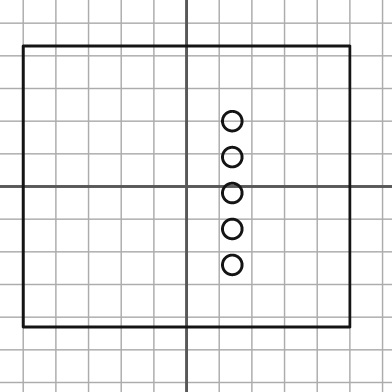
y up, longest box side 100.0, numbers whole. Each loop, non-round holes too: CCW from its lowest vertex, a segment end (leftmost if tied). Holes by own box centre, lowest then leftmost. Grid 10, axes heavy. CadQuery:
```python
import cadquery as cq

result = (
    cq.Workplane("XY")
    .moveTo(-50.0, -43.0)
    .lineTo(50.0, -43.0)
    .lineTo(50.0, 43.0)
    .lineTo(-50.0, 43.0)
    .close()
    .moveTo(14.0, -24.0)
    .circle(3.0)
    .moveTo(14.0, -13.0)
    .circle(3.0)
    .moveTo(14.0, -2.0)
    .circle(3.0)
    .moveTo(14.0, 9.0)
    .circle(3.0)
    .moveTo(14.0, 20.0)
    .circle(3.0)
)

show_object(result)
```